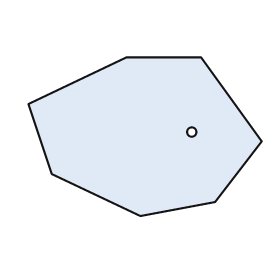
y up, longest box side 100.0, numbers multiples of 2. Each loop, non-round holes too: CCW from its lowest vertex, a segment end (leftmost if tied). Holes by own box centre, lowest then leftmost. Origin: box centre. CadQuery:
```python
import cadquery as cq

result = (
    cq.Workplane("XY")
    .moveTo(-2.0, -34.0)
    .lineTo(30.0, -28.0)
    .lineTo(50.0, -2.0)
    .lineTo(24.0, 34.0)
    .lineTo(-8.0, 34.0)
    .lineTo(-50.0, 14.0)
    .lineTo(-40.0, -16.0)
    .close()
    .moveTo(20.0, 2.0)
    .circle(2.0)
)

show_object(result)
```